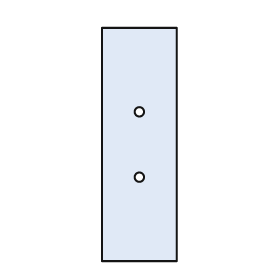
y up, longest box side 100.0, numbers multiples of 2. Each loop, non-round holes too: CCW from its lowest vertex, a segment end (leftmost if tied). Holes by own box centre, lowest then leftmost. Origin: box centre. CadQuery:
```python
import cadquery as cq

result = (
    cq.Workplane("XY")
    .moveTo(-16.0, -50.0)
    .lineTo(16.0, -50.0)
    .lineTo(16.0, 50.0)
    .lineTo(-16.0, 50.0)
    .close()
    .moveTo(0.0, -14.0)
    .circle(2.0)
    .moveTo(0.0, 14.0)
    .circle(2.0)
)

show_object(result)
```